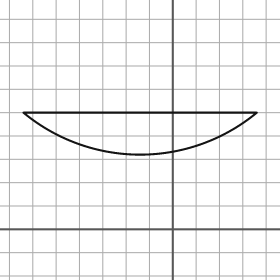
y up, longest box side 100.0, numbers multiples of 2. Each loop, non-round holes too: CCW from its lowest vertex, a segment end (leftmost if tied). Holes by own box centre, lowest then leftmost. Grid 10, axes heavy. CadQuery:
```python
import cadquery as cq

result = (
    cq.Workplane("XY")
    .moveTo(-64.0, 50.0)
    .threePointArc((-14.0, 32.0), (36.0, 50.0))
    .close()
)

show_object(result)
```